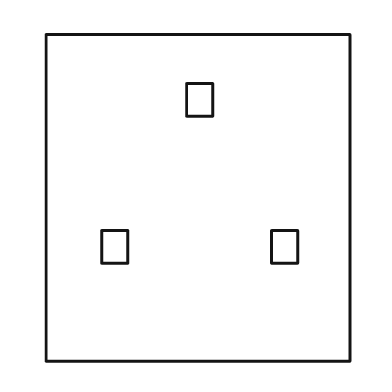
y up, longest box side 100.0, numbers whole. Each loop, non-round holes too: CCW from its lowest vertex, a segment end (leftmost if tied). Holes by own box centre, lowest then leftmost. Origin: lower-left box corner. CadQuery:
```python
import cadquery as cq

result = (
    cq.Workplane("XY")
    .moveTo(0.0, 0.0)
    .lineTo(93.0, 0.0)
    .lineTo(93.0, 100.0)
    .lineTo(0.0, 100.0)
    .close()
    .moveTo(17.0, 30.0)
    .lineTo(25.0, 30.0)
    .lineTo(25.0, 40.0)
    .lineTo(17.0, 40.0)
    .close()
    .moveTo(69.0, 30.0)
    .lineTo(77.0, 30.0)
    .lineTo(77.0, 40.0)
    .lineTo(69.0, 40.0)
    .close()
    .moveTo(43.0, 75.0)
    .lineTo(51.0, 75.0)
    .lineTo(51.0, 85.0)
    .lineTo(43.0, 85.0)
    .close()
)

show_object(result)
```